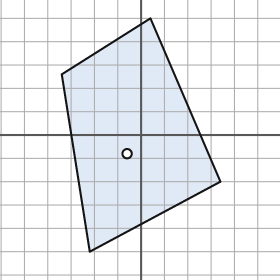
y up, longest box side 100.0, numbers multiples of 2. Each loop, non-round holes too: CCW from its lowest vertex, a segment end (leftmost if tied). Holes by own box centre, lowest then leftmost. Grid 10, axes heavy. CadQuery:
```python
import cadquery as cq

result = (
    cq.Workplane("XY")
    .moveTo(-22.0, -50.0)
    .lineTo(34.0, -20.0)
    .lineTo(4.0, 50.0)
    .lineTo(-34.0, 26.0)
    .close()
    .moveTo(-6.0, -8.0)
    .circle(2.0)
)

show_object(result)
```